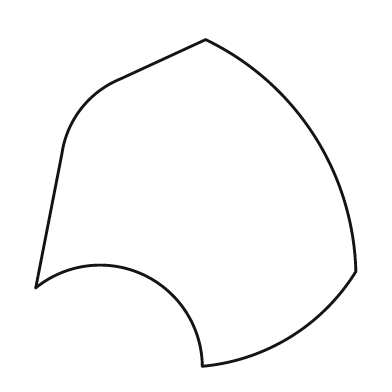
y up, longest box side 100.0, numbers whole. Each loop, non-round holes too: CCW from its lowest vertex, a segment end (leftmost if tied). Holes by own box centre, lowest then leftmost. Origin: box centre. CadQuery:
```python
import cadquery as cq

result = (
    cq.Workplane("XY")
    .moveTo(2.0, -50.0)
    .threePointArc((29.0, -41.0), (49.0, -21.0))
    .threePointArc((36.0, 21.0), (3.0, 50.0))
    .lineTo(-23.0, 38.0)
    .threePointArc((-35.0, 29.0), (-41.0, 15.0))
    .lineTo(-49.0, -26.0)
    .threePointArc((-16.0, -22.0), (2.0, -50.0))
    .close()
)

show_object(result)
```